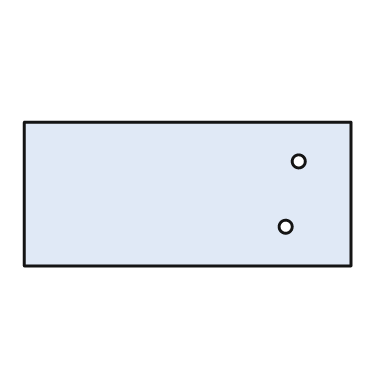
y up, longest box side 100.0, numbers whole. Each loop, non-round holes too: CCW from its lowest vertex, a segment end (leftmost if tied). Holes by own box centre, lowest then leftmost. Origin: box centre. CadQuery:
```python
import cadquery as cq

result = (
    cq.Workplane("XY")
    .moveTo(-50.0, -22.0)
    .lineTo(50.0, -22.0)
    .lineTo(50.0, 22.0)
    .lineTo(-50.0, 22.0)
    .close()
    .moveTo(30.0, -10.0)
    .circle(2.0)
    .moveTo(34.0, 10.0)
    .circle(2.0)
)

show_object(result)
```